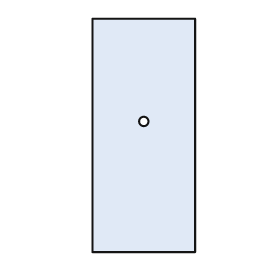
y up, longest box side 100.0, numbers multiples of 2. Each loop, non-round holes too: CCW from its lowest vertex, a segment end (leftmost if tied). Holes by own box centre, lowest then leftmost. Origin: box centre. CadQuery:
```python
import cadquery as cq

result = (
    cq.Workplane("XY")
    .moveTo(-22.0, -50.0)
    .lineTo(22.0, -50.0)
    .lineTo(22.0, 50.0)
    .lineTo(-22.0, 50.0)
    .close()
    .moveTo(0.0, 6.0)
    .circle(2.0)
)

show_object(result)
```